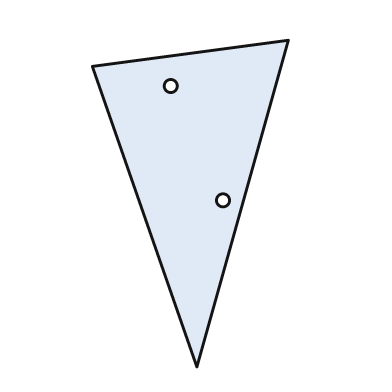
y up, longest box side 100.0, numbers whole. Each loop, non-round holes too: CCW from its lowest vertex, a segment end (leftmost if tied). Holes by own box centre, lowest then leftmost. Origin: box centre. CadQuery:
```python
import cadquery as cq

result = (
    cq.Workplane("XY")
    .moveTo(2.0, -50.0)
    .lineTo(30.0, 50.0)
    .lineTo(-30.0, 42.0)
    .close()
    .moveTo(10.0, 1.0)
    .circle(2.0)
    .moveTo(-6.0, 36.0)
    .circle(2.0)
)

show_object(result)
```